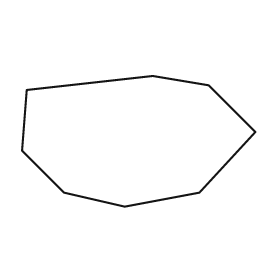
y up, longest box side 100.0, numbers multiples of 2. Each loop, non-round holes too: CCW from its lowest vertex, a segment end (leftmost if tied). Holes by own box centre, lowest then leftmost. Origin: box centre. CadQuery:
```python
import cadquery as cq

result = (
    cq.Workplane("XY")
    .moveTo(-6.0, -28.0)
    .lineTo(26.0, -22.0)
    .lineTo(50.0, 4.0)
    .lineTo(30.0, 24.0)
    .lineTo(6.0, 28.0)
    .lineTo(-48.0, 22.0)
    .lineTo(-50.0, -4.0)
    .lineTo(-32.0, -22.0)
    .close()
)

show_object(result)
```